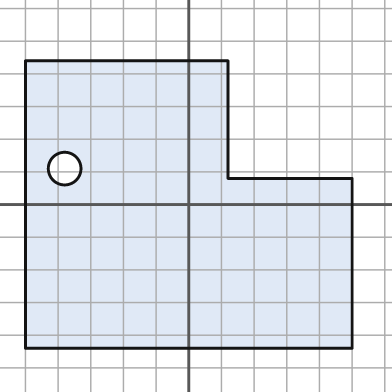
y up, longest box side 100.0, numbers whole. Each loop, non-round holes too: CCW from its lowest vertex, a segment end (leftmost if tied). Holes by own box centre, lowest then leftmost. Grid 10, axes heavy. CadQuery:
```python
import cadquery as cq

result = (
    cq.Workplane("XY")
    .moveTo(-50.0, -44.0)
    .lineTo(50.0, -44.0)
    .lineTo(50.0, 8.0)
    .lineTo(12.0, 8.0)
    .lineTo(12.0, 44.0)
    .lineTo(-50.0, 44.0)
    .close()
    .moveTo(-38.0, 11.0)
    .circle(5.0)
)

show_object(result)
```